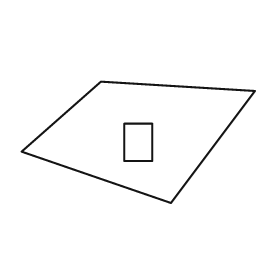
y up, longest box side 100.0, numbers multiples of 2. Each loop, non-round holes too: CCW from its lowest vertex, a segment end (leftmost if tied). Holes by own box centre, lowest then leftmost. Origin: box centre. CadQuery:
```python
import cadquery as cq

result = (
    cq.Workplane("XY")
    .moveTo(14.0, -26.0)
    .lineTo(50.0, 22.0)
    .lineTo(-16.0, 26.0)
    .lineTo(-50.0, -4.0)
    .close()
    .moveTo(-6.0, -8.0)
    .lineTo(6.0, -8.0)
    .lineTo(6.0, 8.0)
    .lineTo(-6.0, 8.0)
    .close()
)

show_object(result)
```